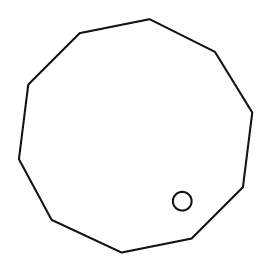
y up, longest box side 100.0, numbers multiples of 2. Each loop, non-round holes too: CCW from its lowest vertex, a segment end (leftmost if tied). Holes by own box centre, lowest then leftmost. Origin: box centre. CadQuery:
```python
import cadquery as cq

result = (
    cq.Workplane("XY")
    .moveTo(-6.0, -50.0)
    .lineTo(24.0, -44.0)
    .lineTo(46.0, -22.0)
    .lineTo(50.0, 10.0)
    .lineTo(34.0, 36.0)
    .lineTo(6.0, 50.0)
    .lineTo(-24.0, 44.0)
    .lineTo(-46.0, 22.0)
    .lineTo(-50.0, -10.0)
    .lineTo(-36.0, -36.0)
    .close()
    .moveTo(20.0, -28.0)
    .circle(4.0)
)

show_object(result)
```